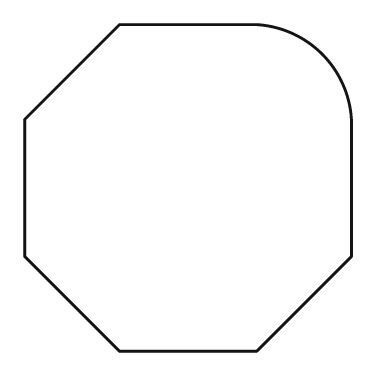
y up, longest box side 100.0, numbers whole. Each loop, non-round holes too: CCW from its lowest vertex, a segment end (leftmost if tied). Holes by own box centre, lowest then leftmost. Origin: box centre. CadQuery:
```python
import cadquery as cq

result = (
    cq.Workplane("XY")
    .moveTo(-21.0, -50.0)
    .lineTo(21.0, -50.0)
    .lineTo(50.0, -21.0)
    .lineTo(50.0, 21.0)
    .threePointArc((41.0, 41.0), (21.0, 50.0))
    .lineTo(-21.0, 50.0)
    .lineTo(-50.0, 21.0)
    .lineTo(-50.0, -21.0)
    .close()
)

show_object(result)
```